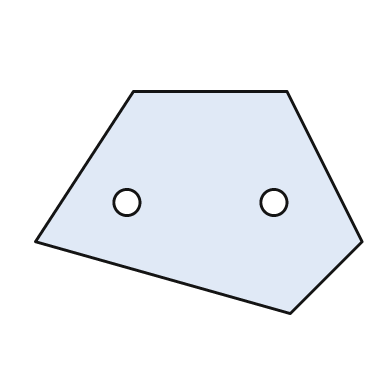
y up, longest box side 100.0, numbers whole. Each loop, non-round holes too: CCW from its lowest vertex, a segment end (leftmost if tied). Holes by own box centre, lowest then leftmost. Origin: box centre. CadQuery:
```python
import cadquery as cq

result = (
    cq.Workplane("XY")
    .moveTo(28.0, -34.0)
    .lineTo(50.0, -12.0)
    .lineTo(27.0, 34.0)
    .lineTo(-20.0, 34.0)
    .lineTo(-50.0, -12.0)
    .close()
    .moveTo(-22.0, 0.0)
    .circle(4.0)
    .moveTo(23.0, 0.0)
    .circle(4.0)
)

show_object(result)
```